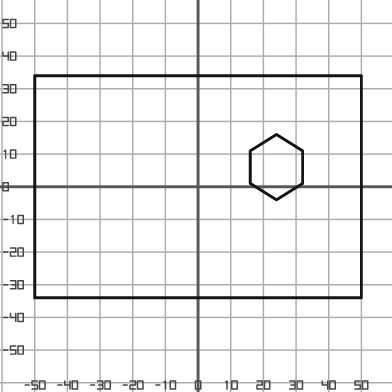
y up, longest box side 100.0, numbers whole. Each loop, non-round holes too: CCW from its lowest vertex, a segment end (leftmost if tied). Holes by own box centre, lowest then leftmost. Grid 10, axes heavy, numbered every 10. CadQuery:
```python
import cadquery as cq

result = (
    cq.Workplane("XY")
    .moveTo(-50.0, -34.0)
    .lineTo(50.0, -34.0)
    .lineTo(50.0, 34.0)
    .lineTo(-50.0, 34.0)
    .close()
    .moveTo(24.0, -4.0)
    .lineTo(32.0, 1.0)
    .lineTo(32.0, 11.0)
    .lineTo(24.0, 16.0)
    .lineTo(16.0, 11.0)
    .lineTo(16.0, 1.0)
    .close()
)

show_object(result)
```